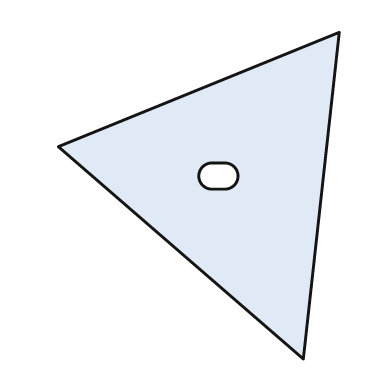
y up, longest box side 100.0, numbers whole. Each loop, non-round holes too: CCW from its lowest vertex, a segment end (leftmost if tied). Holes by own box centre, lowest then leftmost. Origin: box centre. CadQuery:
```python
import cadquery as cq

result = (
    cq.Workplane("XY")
    .moveTo(32.0, -50.0)
    .lineTo(43.0, 50.0)
    .lineTo(-43.0, 15.0)
    .close()
    .moveTo(4.0, 2.0)
    .lineTo(8.0, 2.0)
    .threePointArc((12.0, 6.0), (8.0, 10.0))
    .lineTo(4.0, 10.0)
    .threePointArc((0.0, 6.0), (4.0, 2.0))
    .close()
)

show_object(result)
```